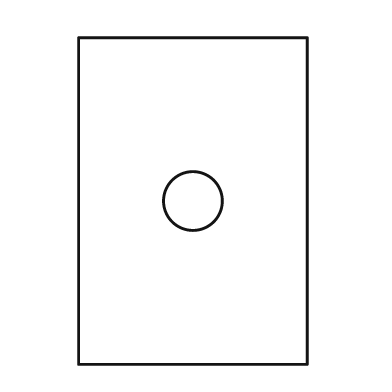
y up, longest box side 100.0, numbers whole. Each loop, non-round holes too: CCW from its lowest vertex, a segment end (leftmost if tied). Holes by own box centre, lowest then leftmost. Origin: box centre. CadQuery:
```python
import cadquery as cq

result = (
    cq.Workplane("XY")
    .moveTo(-35.0, -50.0)
    .lineTo(35.0, -50.0)
    .lineTo(35.0, 50.0)
    .lineTo(-35.0, 50.0)
    .close()
    .moveTo(0.0, 0.0)
    .circle(9.0)
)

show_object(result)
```